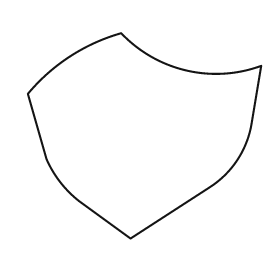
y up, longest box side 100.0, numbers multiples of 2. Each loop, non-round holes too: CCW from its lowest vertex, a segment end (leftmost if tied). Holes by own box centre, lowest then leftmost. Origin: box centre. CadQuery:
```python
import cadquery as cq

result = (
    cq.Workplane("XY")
    .moveTo(-6.0, -44.0)
    .lineTo(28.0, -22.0)
    .threePointArc((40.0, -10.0), (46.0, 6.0))
    .lineTo(50.0, 30.0)
    .threePointArc((18.0, 28.0), (-10.0, 44.0))
    .threePointArc((-32.0, 34.0), (-50.0, 18.0))
    .lineTo(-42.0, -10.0)
    .threePointArc((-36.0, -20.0), (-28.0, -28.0))
    .close()
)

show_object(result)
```